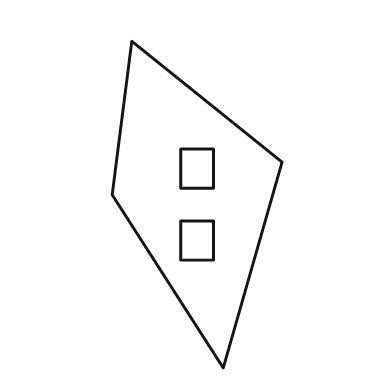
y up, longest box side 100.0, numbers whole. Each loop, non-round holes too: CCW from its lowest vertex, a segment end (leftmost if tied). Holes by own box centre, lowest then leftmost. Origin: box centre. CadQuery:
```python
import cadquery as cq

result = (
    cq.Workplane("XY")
    .moveTo(8.0, -50.0)
    .lineTo(26.0, 13.0)
    .lineTo(-20.0, 50.0)
    .lineTo(-26.0, 3.0)
    .close()
    .moveTo(-5.0, -17.0)
    .lineTo(5.0, -17.0)
    .lineTo(5.0, -5.0)
    .lineTo(-5.0, -5.0)
    .close()
    .moveTo(-5.0, 5.0)
    .lineTo(5.0, 5.0)
    .lineTo(5.0, 17.0)
    .lineTo(-5.0, 17.0)
    .close()
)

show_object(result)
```